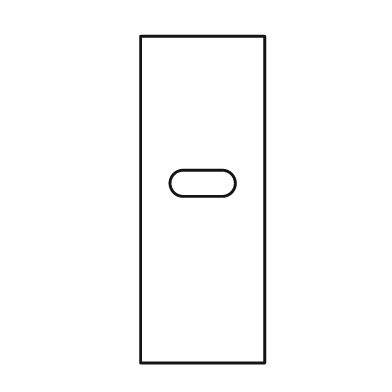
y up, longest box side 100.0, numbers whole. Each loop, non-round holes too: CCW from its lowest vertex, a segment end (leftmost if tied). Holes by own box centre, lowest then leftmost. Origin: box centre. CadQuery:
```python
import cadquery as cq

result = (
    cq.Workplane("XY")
    .moveTo(-19.0, -50.0)
    .lineTo(19.0, -50.0)
    .lineTo(19.0, 50.0)
    .lineTo(-19.0, 50.0)
    .close()
    .moveTo(-6.0, 1.0)
    .lineTo(6.0, 1.0)
    .threePointArc((10.0, 5.0), (6.0, 9.0))
    .lineTo(-6.0, 9.0)
    .threePointArc((-10.0, 5.0), (-6.0, 1.0))
    .close()
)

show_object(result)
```